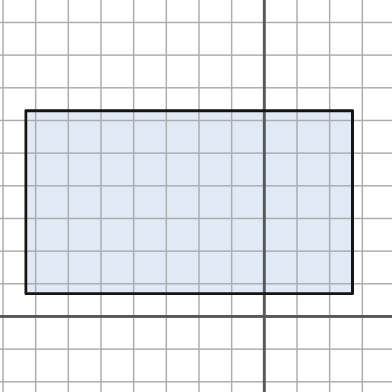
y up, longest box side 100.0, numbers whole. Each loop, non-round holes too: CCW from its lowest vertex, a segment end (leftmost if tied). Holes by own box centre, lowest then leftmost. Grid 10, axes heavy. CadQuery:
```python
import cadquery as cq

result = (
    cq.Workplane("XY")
    .moveTo(-73.0, 7.0)
    .lineTo(27.0, 7.0)
    .lineTo(27.0, 63.0)
    .lineTo(-73.0, 63.0)
    .close()
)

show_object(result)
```